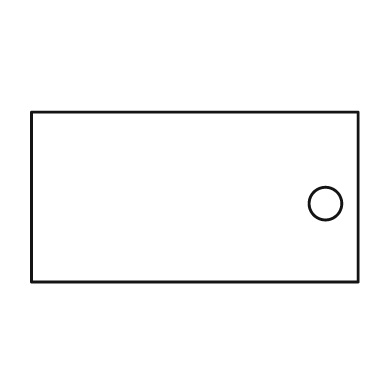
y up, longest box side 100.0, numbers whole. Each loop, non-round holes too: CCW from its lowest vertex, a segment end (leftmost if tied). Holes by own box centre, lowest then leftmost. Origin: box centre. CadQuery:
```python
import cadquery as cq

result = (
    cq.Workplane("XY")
    .moveTo(-50.0, -26.0)
    .lineTo(50.0, -26.0)
    .lineTo(50.0, 26.0)
    .lineTo(-50.0, 26.0)
    .close()
    .moveTo(40.0, -2.0)
    .circle(5.0)
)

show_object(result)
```